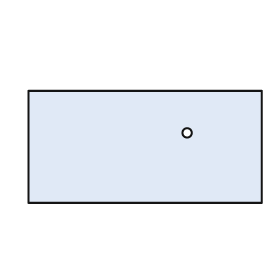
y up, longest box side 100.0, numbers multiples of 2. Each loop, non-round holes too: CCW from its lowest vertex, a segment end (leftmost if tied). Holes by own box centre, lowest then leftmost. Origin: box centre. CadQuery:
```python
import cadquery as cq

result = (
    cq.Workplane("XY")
    .moveTo(-50.0, -24.0)
    .lineTo(50.0, -24.0)
    .lineTo(50.0, 24.0)
    .lineTo(-50.0, 24.0)
    .close()
    .moveTo(18.0, 6.0)
    .circle(2.0)
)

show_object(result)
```